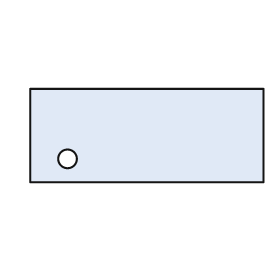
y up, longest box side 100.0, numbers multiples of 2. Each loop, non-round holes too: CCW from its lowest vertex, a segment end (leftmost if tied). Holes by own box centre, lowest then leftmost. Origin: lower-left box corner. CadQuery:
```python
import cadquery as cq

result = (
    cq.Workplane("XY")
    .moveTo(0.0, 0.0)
    .lineTo(100.0, 0.0)
    .lineTo(100.0, 40.0)
    .lineTo(0.0, 40.0)
    .close()
    .moveTo(16.0, 10.0)
    .circle(4.0)
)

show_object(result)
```